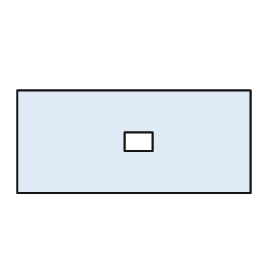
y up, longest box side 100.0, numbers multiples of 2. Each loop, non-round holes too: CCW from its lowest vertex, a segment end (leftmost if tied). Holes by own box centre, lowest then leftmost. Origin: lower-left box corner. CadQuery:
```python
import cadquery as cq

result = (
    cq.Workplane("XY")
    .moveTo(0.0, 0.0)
    .lineTo(100.0, 0.0)
    .lineTo(100.0, 44.0)
    .lineTo(0.0, 44.0)
    .close()
    .moveTo(46.0, 18.0)
    .lineTo(58.0, 18.0)
    .lineTo(58.0, 26.0)
    .lineTo(46.0, 26.0)
    .close()
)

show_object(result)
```